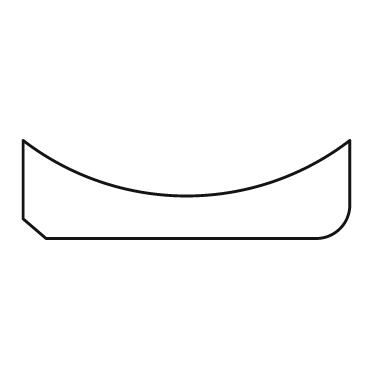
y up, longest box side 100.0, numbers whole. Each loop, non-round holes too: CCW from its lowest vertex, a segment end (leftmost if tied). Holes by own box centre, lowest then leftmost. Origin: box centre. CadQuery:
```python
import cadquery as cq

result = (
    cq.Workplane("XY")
    .moveTo(-43.0, -15.0)
    .lineTo(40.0, -15.0)
    .threePointArc((47.0, -12.0), (50.0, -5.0))
    .lineTo(50.0, 15.0)
    .threePointArc((0.0, -2.0), (-50.0, 15.0))
    .lineTo(-50.0, -9.0)
    .close()
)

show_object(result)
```